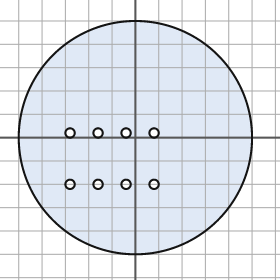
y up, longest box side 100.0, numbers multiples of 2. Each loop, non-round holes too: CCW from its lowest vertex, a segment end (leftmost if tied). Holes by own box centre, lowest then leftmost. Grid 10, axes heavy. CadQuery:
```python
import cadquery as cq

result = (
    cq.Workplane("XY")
    .moveTo(0.0, 0.0)
    .circle(50.0)
    .moveTo(-28.0, -20.0)
    .circle(2.0)
    .moveTo(-16.0, -20.0)
    .circle(2.0)
    .moveTo(-4.0, -20.0)
    .circle(2.0)
    .moveTo(8.0, -20.0)
    .circle(2.0)
    .moveTo(-28.0, 2.0)
    .circle(2.0)
    .moveTo(-16.0, 2.0)
    .circle(2.0)
    .moveTo(-4.0, 2.0)
    .circle(2.0)
    .moveTo(8.0, 2.0)
    .circle(2.0)
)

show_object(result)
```